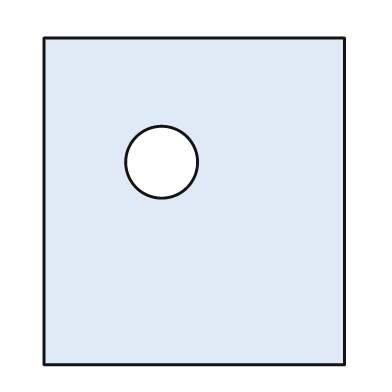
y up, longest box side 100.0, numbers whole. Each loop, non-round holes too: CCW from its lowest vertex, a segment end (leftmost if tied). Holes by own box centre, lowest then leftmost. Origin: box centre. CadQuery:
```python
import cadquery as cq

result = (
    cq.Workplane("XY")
    .moveTo(-46.0, -50.0)
    .lineTo(46.0, -50.0)
    .lineTo(46.0, 50.0)
    .lineTo(-46.0, 50.0)
    .close()
    .moveTo(-10.0, 12.0)
    .circle(11.0)
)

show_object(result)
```